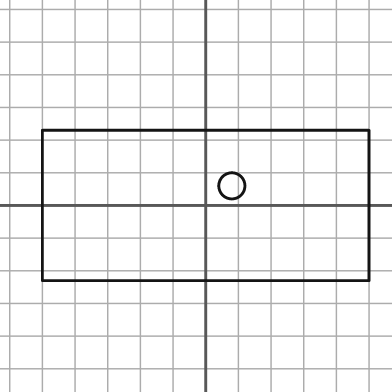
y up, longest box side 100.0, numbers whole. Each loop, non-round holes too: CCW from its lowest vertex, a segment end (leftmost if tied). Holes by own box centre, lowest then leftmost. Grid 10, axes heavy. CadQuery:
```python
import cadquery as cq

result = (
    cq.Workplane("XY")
    .moveTo(-50.0, -23.0)
    .lineTo(50.0, -23.0)
    .lineTo(50.0, 23.0)
    .lineTo(-50.0, 23.0)
    .close()
    .moveTo(8.0, 6.0)
    .circle(4.0)
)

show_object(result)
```